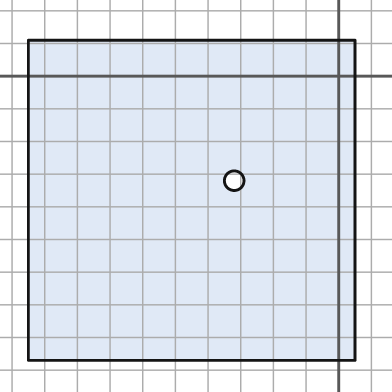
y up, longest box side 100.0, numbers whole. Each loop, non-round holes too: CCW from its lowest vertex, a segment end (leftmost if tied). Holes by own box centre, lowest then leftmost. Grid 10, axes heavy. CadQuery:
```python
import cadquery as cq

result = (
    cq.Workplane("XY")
    .moveTo(-95.0, -87.0)
    .lineTo(5.0, -87.0)
    .lineTo(5.0, 11.0)
    .lineTo(-95.0, 11.0)
    .close()
    .moveTo(-32.0, -32.0)
    .circle(3.0)
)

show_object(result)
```